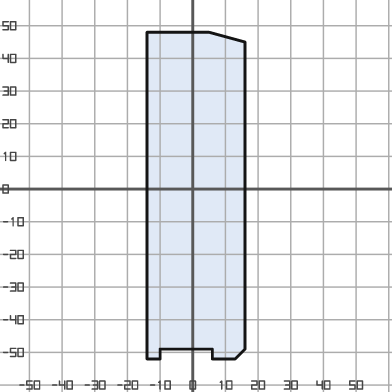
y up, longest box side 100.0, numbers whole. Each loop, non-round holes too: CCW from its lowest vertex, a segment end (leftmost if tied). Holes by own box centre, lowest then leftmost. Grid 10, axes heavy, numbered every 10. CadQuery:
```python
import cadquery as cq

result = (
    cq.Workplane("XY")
    .moveTo(-14.0, -52.0)
    .lineTo(-10.0, -52.0)
    .lineTo(-10.0, -49.0)
    .lineTo(6.0, -49.0)
    .lineTo(6.0, -52.0)
    .lineTo(13.0, -52.0)
    .lineTo(16.0, -49.0)
    .lineTo(16.0, 45.0)
    .lineTo(5.0, 48.0)
    .lineTo(-14.0, 48.0)
    .close()
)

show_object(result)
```